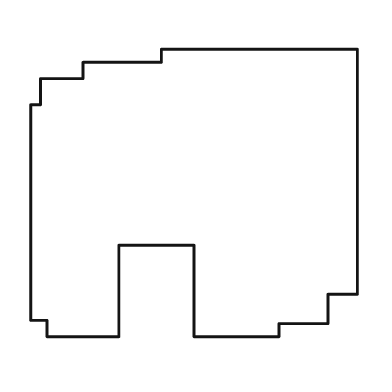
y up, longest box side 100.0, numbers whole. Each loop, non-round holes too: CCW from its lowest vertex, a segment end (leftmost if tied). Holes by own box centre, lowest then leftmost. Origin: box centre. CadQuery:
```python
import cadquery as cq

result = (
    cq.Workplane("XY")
    .moveTo(-45.0, -44.0)
    .lineTo(-23.0, -44.0)
    .lineTo(-23.0, -16.0)
    .lineTo(0.0, -16.0)
    .lineTo(0.0, -44.0)
    .lineTo(26.0, -44.0)
    .lineTo(26.0, -40.0)
    .lineTo(41.0, -40.0)
    .lineTo(41.0, -31.0)
    .lineTo(50.0, -31.0)
    .lineTo(50.0, 44.0)
    .lineTo(-10.0, 44.0)
    .lineTo(-10.0, 40.0)
    .lineTo(-34.0, 40.0)
    .lineTo(-34.0, 35.0)
    .lineTo(-47.0, 35.0)
    .lineTo(-47.0, 27.0)
    .lineTo(-50.0, 27.0)
    .lineTo(-50.0, -39.0)
    .lineTo(-45.0, -39.0)
    .close()
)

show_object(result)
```